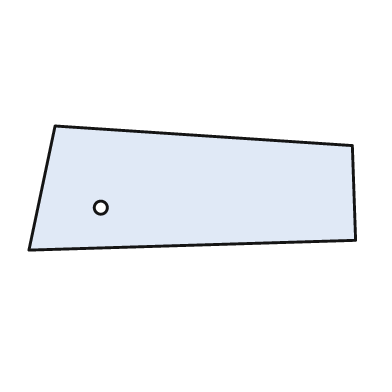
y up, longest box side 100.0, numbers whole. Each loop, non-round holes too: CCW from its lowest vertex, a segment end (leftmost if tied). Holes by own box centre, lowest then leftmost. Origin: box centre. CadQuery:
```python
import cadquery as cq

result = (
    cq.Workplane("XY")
    .moveTo(-50.0, -19.0)
    .lineTo(50.0, -16.0)
    .lineTo(49.0, 13.0)
    .lineTo(-42.0, 19.0)
    .close()
    .moveTo(-28.0, -6.0)
    .circle(2.0)
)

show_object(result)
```